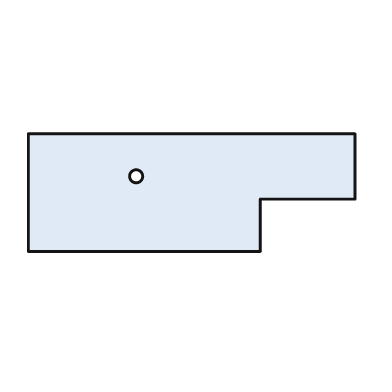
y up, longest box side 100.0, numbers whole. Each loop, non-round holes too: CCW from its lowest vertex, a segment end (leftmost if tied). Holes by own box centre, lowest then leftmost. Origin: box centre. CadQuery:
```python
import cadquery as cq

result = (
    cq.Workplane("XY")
    .moveTo(-50.0, -18.0)
    .lineTo(21.0, -18.0)
    .lineTo(21.0, -2.0)
    .lineTo(50.0, -2.0)
    .lineTo(50.0, 18.0)
    .lineTo(-50.0, 18.0)
    .close()
    .moveTo(-17.0, 5.0)
    .circle(2.0)
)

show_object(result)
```